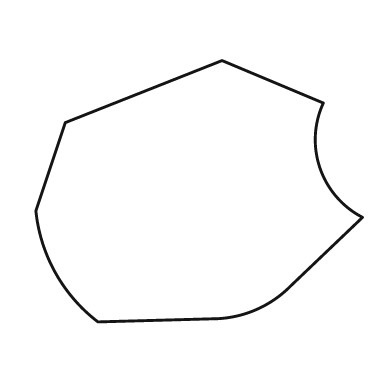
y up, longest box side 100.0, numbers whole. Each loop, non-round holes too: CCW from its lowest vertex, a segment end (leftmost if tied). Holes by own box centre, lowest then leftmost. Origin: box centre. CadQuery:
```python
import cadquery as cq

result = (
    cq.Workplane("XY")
    .moveTo(-31.0, -40.0)
    .lineTo(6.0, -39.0)
    .threePointArc((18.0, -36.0), (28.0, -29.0))
    .lineTo(50.0, -8.0)
    .threePointArc((37.0, 7.0), (38.0, 27.0))
    .lineTo(7.0, 40.0)
    .lineTo(-41.0, 21.0)
    .lineTo(-50.0, -6.0)
    .threePointArc((-44.0, -25.0), (-31.0, -40.0))
    .close()
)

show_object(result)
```